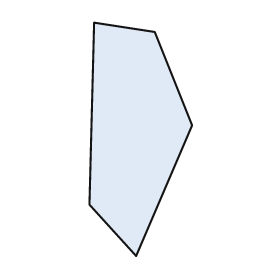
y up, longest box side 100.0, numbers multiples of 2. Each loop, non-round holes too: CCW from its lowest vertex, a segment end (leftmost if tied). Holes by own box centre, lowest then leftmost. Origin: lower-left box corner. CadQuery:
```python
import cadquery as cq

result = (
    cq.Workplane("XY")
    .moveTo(20.0, 0.0)
    .lineTo(44.0, 56.0)
    .lineTo(28.0, 96.0)
    .lineTo(2.0, 100.0)
    .lineTo(0.0, 22.0)
    .close()
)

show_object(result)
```